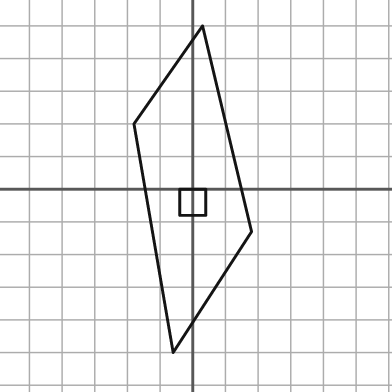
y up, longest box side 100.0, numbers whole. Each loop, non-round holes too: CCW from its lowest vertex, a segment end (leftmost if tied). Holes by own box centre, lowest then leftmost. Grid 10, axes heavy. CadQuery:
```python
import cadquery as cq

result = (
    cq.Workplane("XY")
    .moveTo(-6.0, -50.0)
    .lineTo(18.0, -13.0)
    .lineTo(3.0, 50.0)
    .lineTo(-18.0, 20.0)
    .close()
    .moveTo(-4.0, -8.0)
    .lineTo(4.0, -8.0)
    .lineTo(4.0, 0.0)
    .lineTo(-4.0, 0.0)
    .close()
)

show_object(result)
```